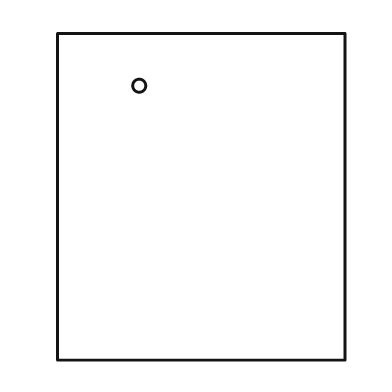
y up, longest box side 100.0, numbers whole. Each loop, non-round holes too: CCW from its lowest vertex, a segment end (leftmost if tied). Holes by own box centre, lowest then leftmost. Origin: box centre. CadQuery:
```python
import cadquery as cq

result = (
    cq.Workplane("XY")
    .moveTo(-44.0, -50.0)
    .lineTo(44.0, -50.0)
    .lineTo(44.0, 50.0)
    .lineTo(-44.0, 50.0)
    .close()
    .moveTo(-19.0, 34.0)
    .circle(2.0)
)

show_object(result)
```